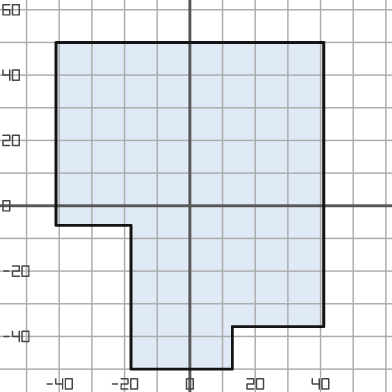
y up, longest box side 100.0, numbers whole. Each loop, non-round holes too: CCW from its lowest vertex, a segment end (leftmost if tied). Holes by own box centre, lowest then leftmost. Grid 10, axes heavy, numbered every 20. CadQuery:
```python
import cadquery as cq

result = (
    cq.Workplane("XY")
    .moveTo(-18.0, -50.0)
    .lineTo(13.0, -50.0)
    .lineTo(13.0, -37.0)
    .lineTo(41.0, -37.0)
    .lineTo(41.0, 50.0)
    .lineTo(-41.0, 50.0)
    .lineTo(-41.0, -6.0)
    .lineTo(-18.0, -6.0)
    .close()
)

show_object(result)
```